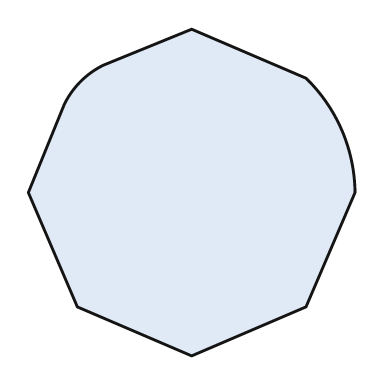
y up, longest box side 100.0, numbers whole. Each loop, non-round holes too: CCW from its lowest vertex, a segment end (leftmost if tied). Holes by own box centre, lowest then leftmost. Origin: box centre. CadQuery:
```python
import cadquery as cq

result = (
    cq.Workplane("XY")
    .moveTo(0.0, -50.0)
    .lineTo(35.0, -35.0)
    .lineTo(50.0, 0.0)
    .threePointArc((46.0, 19.0), (35.0, 35.0))
    .lineTo(0.0, 50.0)
    .lineTo(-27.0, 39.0)
    .threePointArc((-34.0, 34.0), (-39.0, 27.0))
    .lineTo(-50.0, 0.0)
    .lineTo(-35.0, -35.0)
    .close()
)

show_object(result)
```